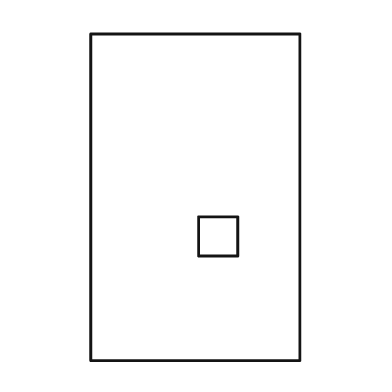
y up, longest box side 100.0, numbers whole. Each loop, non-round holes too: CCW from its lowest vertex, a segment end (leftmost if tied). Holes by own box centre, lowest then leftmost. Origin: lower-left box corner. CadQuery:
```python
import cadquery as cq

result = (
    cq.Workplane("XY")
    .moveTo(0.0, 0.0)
    .lineTo(64.0, 0.0)
    .lineTo(64.0, 100.0)
    .lineTo(0.0, 100.0)
    .close()
    .moveTo(33.0, 32.0)
    .lineTo(45.0, 32.0)
    .lineTo(45.0, 44.0)
    .lineTo(33.0, 44.0)
    .close()
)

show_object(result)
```